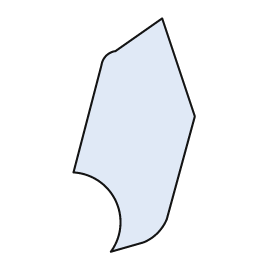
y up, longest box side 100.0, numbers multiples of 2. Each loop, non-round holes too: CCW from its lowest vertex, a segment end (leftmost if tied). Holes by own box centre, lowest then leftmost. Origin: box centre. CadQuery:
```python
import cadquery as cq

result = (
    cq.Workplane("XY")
    .moveTo(-10.0, -50.0)
    .lineTo(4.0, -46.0)
    .threePointArc((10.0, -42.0), (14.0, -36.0))
    .lineTo(26.0, 8.0)
    .lineTo(12.0, 50.0)
    .lineTo(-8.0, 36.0)
    .threePointArc((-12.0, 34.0), (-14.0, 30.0))
    .lineTo(-26.0, -16.0)
    .threePointArc((-8.0, -28.0), (-10.0, -50.0))
    .close()
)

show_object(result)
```